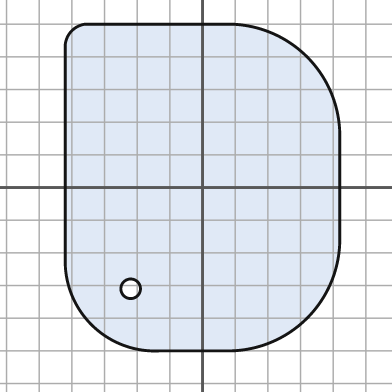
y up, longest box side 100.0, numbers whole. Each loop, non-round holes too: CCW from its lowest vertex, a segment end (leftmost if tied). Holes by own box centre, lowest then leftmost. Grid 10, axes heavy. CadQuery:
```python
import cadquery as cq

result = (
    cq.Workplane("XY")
    .moveTo(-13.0, -50.0)
    .lineTo(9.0, -50.0)
    .threePointArc((32.0, -40.0), (42.0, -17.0))
    .lineTo(42.0, 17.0)
    .threePointArc((32.0, 40.0), (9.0, 50.0))
    .lineTo(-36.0, 50.0)
    .threePointArc((-40.0, 48.0), (-42.0, 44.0))
    .lineTo(-42.0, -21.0)
    .threePointArc((-34.0, -42.0), (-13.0, -50.0))
    .close()
    .moveTo(-22.0, -31.0)
    .circle(3.0)
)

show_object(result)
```